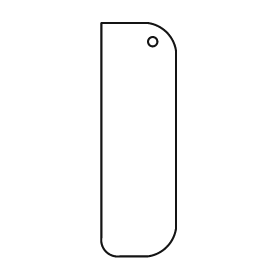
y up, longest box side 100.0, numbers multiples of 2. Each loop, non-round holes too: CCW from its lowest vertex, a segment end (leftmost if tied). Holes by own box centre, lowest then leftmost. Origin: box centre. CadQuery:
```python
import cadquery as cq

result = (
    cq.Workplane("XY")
    .moveTo(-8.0, -50.0)
    .lineTo(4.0, -50.0)
    .threePointArc((12.0, -46.0), (16.0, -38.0))
    .lineTo(16.0, 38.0)
    .threePointArc((12.0, 46.0), (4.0, 50.0))
    .lineTo(-16.0, 50.0)
    .lineTo(-16.0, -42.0)
    .threePointArc((-14.0, -48.0), (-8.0, -50.0))
    .close()
    .moveTo(6.0, 42.0)
    .circle(2.0)
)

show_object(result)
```